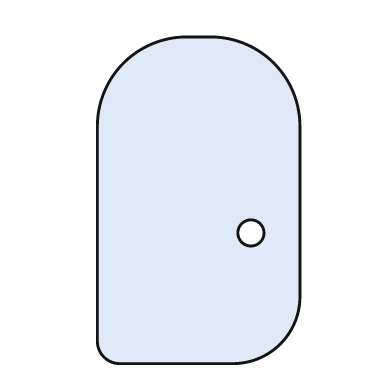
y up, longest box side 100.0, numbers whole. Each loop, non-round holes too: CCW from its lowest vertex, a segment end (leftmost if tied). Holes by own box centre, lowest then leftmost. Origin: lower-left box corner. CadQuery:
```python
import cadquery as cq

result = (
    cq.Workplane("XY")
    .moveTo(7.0, 0.0)
    .lineTo(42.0, 0.0)
    .threePointArc((56.0, 6.0), (62.0, 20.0))
    .lineTo(62.0, 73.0)
    .threePointArc((54.0, 92.0), (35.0, 100.0))
    .lineTo(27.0, 100.0)
    .threePointArc((8.0, 92.0), (0.0, 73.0))
    .lineTo(0.0, 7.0)
    .threePointArc((2.0, 2.0), (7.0, 0.0))
    .close()
    .moveTo(47.0, 40.0)
    .circle(4.0)
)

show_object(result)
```